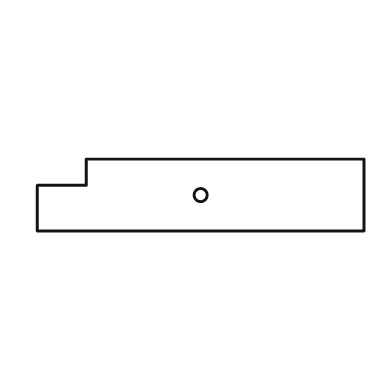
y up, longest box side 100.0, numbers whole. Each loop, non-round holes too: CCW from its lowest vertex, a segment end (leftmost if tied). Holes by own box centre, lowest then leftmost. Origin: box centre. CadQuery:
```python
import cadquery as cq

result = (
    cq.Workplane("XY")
    .moveTo(-50.0, -11.0)
    .lineTo(50.0, -11.0)
    .lineTo(50.0, 11.0)
    .lineTo(-35.0, 11.0)
    .lineTo(-35.0, 3.0)
    .lineTo(-50.0, 3.0)
    .close()
    .moveTo(0.0, 0.0)
    .circle(2.0)
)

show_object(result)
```